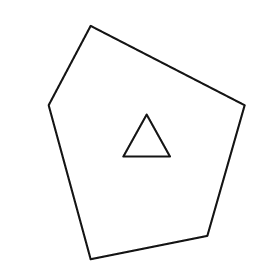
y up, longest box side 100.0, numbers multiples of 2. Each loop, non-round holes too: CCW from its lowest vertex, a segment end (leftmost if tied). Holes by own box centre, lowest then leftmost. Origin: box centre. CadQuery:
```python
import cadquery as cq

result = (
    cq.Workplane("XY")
    .moveTo(-24.0, -50.0)
    .lineTo(26.0, -40.0)
    .lineTo(42.0, 16.0)
    .lineTo(-24.0, 50.0)
    .lineTo(-42.0, 16.0)
    .close()
    .moveTo(-10.0, -6.0)
    .lineTo(10.0, -6.0)
    .lineTo(0.0, 12.0)
    .close()
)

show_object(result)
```